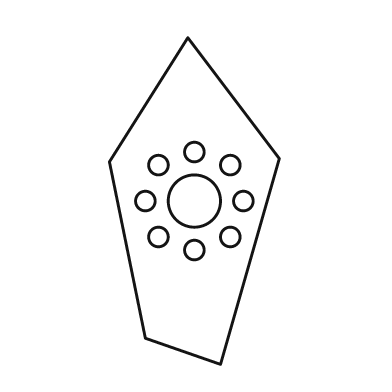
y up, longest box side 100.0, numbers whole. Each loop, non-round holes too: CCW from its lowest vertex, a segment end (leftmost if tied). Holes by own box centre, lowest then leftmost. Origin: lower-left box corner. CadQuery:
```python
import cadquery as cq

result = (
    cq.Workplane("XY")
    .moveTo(34.0, 0.0)
    .lineTo(52.0, 63.0)
    .lineTo(24.0, 100.0)
    .lineTo(0.0, 62.0)
    .lineTo(11.0, 8.0)
    .close()
    .moveTo(26.0, 35.0)
    .circle(3.0)
    .moveTo(15.0, 39.0)
    .circle(3.0)
    .moveTo(37.0, 39.0)
    .circle(3.0)
    .moveTo(11.0, 50.0)
    .circle(3.0)
    .moveTo(26.0, 50.0)
    .circle(8.0)
    .moveTo(41.0, 50.0)
    .circle(3.0)
    .moveTo(15.0, 61.0)
    .circle(3.0)
    .moveTo(37.0, 61.0)
    .circle(3.0)
    .moveTo(26.0, 65.0)
    .circle(3.0)
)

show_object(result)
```